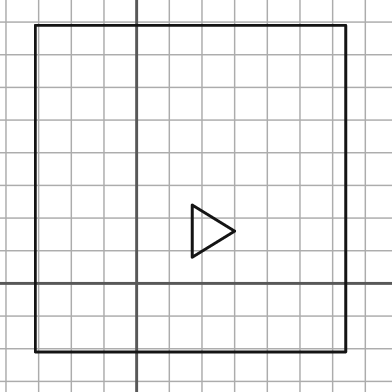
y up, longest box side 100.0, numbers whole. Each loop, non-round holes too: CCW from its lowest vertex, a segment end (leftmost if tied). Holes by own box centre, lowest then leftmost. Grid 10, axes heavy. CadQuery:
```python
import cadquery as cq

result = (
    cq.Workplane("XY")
    .moveTo(-31.0, -21.0)
    .lineTo(64.0, -21.0)
    .lineTo(64.0, 79.0)
    .lineTo(-31.0, 79.0)
    .close()
    .moveTo(17.0, 8.0)
    .lineTo(30.0, 16.0)
    .lineTo(17.0, 24.0)
    .close()
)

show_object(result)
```